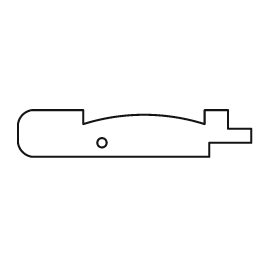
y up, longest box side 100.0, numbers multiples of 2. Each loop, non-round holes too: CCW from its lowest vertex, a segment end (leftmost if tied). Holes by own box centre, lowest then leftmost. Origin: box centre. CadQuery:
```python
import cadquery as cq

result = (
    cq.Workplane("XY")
    .moveTo(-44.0, -10.0)
    .lineTo(32.0, -10.0)
    .lineTo(32.0, -4.0)
    .lineTo(50.0, -4.0)
    .lineTo(50.0, 2.0)
    .lineTo(40.0, 2.0)
    .lineTo(40.0, 10.0)
    .lineTo(30.0, 10.0)
    .lineTo(30.0, 4.0)
    .threePointArc((4.0, 8.0), (-22.0, 4.0))
    .lineTo(-22.0, 10.0)
    .lineTo(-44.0, 10.0)
    .threePointArc((-48.0, 8.0), (-50.0, 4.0))
    .lineTo(-50.0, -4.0)
    .threePointArc((-48.0, -8.0), (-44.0, -10.0))
    .close()
    .moveTo(-14.0, -4.0)
    .circle(2.0)
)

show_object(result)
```